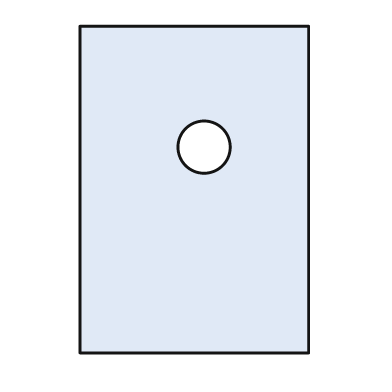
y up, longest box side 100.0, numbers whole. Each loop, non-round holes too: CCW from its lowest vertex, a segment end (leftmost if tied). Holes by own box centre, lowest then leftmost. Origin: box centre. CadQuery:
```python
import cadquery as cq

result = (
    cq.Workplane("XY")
    .moveTo(-35.0, -50.0)
    .lineTo(35.0, -50.0)
    .lineTo(35.0, 50.0)
    .lineTo(-35.0, 50.0)
    .close()
    .moveTo(3.0, 13.0)
    .circle(8.0)
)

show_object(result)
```